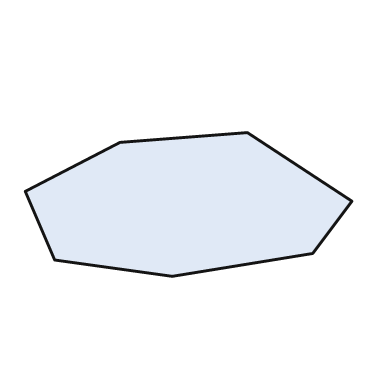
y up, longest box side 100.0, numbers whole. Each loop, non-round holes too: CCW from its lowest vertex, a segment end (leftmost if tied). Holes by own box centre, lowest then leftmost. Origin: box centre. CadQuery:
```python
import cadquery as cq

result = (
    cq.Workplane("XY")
    .moveTo(-5.0, -22.0)
    .lineTo(38.0, -15.0)
    .lineTo(50.0, 1.0)
    .lineTo(18.0, 22.0)
    .lineTo(-21.0, 19.0)
    .lineTo(-50.0, 4.0)
    .lineTo(-41.0, -17.0)
    .close()
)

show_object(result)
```